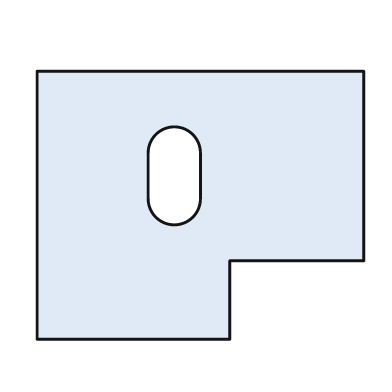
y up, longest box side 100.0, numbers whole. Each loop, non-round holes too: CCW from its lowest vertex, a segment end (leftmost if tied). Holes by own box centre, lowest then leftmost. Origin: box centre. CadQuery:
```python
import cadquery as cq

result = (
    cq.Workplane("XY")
    .moveTo(-50.0, -41.0)
    .lineTo(9.0, -41.0)
    .lineTo(9.0, -17.0)
    .lineTo(50.0, -17.0)
    .lineTo(50.0, 41.0)
    .lineTo(-50.0, 41.0)
    .close()
    .moveTo(-16.0, 2.0)
    .threePointArc((-8.0, -6.0), (0.0, 2.0))
    .lineTo(0.0, 16.0)
    .threePointArc((-8.0, 24.0), (-16.0, 16.0))
    .close()
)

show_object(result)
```